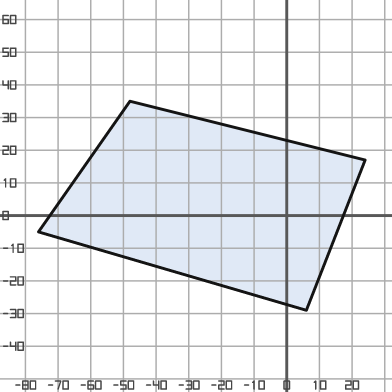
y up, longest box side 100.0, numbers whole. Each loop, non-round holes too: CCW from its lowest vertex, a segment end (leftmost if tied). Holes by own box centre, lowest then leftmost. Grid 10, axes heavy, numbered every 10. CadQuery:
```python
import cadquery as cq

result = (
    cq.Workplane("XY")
    .moveTo(6.0, -29.0)
    .lineTo(24.0, 17.0)
    .lineTo(-48.0, 35.0)
    .lineTo(-76.0, -5.0)
    .close()
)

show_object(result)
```